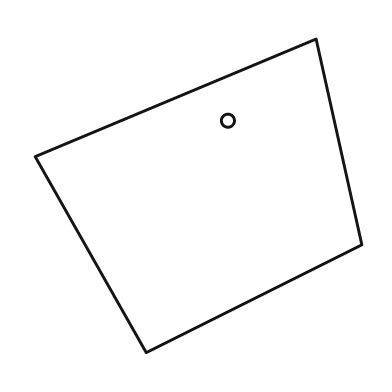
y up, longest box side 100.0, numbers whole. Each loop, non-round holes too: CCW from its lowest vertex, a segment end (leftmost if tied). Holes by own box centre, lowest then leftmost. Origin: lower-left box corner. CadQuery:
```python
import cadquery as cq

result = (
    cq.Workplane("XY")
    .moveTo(34.0, 0.0)
    .lineTo(100.0, 33.0)
    .lineTo(86.0, 96.0)
    .lineTo(0.0, 60.0)
    .close()
    .moveTo(59.0, 71.0)
    .circle(2.0)
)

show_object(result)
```